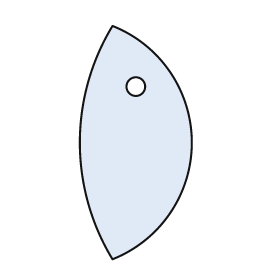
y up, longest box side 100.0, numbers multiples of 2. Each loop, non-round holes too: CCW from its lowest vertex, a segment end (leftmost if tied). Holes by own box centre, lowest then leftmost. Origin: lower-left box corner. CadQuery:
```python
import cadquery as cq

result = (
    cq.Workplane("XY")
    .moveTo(14.0, 0.0)
    .threePointArc((48.0, 50.0), (14.0, 100.0))
    .threePointArc((0.0, 50.0), (14.0, 0.0))
    .close()
    .moveTo(24.0, 74.0)
    .circle(4.0)
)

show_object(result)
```